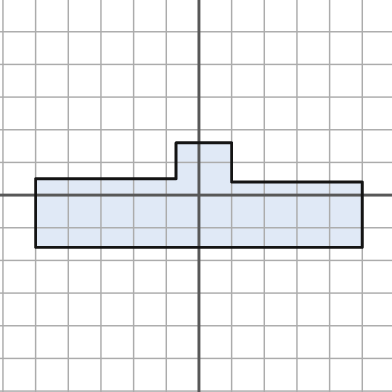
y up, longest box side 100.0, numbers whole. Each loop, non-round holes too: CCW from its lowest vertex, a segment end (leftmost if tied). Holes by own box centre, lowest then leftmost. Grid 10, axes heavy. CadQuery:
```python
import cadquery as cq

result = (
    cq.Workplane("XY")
    .moveTo(-50.0, -16.0)
    .lineTo(50.0, -16.0)
    .lineTo(50.0, 4.0)
    .lineTo(10.0, 4.0)
    .lineTo(10.0, 16.0)
    .lineTo(-7.0, 16.0)
    .lineTo(-7.0, 5.0)
    .lineTo(-50.0, 5.0)
    .close()
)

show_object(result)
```